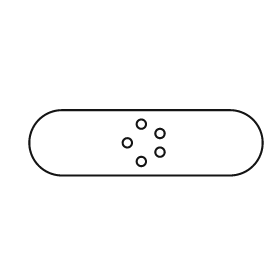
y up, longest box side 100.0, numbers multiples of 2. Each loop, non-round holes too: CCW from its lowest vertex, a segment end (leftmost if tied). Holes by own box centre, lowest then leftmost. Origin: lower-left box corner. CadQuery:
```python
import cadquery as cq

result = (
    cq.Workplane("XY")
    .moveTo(14.0, 0.0)
    .lineTo(86.0, 0.0)
    .threePointArc((100.0, 14.0), (86.0, 28.0))
    .lineTo(14.0, 28.0)
    .threePointArc((0.0, 14.0), (14.0, 0.0))
    .close()
    .moveTo(48.0, 6.0)
    .circle(2.0)
    .moveTo(56.0, 10.0)
    .circle(2.0)
    .moveTo(42.0, 14.0)
    .circle(2.0)
    .moveTo(56.0, 18.0)
    .circle(2.0)
    .moveTo(48.0, 22.0)
    .circle(2.0)
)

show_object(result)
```